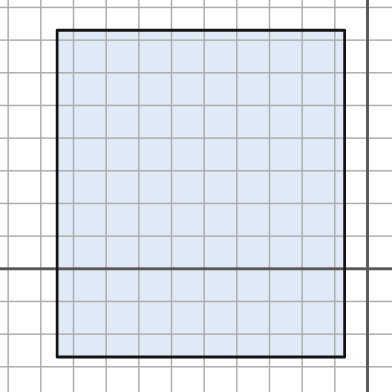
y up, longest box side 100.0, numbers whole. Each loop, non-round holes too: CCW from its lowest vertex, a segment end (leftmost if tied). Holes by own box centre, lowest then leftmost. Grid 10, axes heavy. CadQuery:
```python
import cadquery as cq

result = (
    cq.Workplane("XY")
    .moveTo(-95.0, -27.0)
    .lineTo(-7.0, -27.0)
    .lineTo(-7.0, 73.0)
    .lineTo(-95.0, 73.0)
    .close()
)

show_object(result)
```